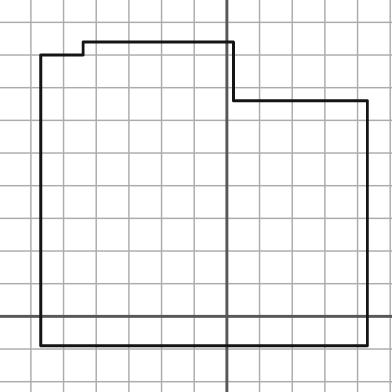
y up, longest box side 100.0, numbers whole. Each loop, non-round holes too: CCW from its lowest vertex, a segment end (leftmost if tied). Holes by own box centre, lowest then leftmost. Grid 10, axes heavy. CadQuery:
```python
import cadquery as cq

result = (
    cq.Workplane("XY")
    .moveTo(-57.0, -9.0)
    .lineTo(43.0, -9.0)
    .lineTo(43.0, 66.0)
    .lineTo(2.0, 66.0)
    .lineTo(2.0, 84.0)
    .lineTo(-44.0, 84.0)
    .lineTo(-44.0, 80.0)
    .lineTo(-57.0, 80.0)
    .close()
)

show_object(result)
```